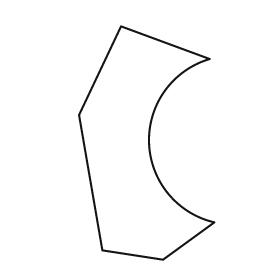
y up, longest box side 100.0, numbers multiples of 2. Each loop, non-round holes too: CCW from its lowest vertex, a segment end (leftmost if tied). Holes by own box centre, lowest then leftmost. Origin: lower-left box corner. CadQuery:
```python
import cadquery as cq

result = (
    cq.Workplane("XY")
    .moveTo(36.0, 0.0)
    .lineTo(58.0, 16.0)
    .threePointArc((30.0, 50.0), (56.0, 86.0))
    .lineTo(18.0, 100.0)
    .lineTo(0.0, 62.0)
    .lineTo(10.0, 4.0)
    .close()
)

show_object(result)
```